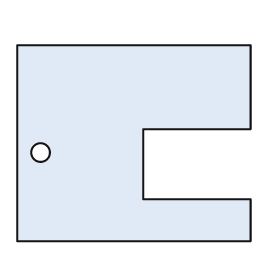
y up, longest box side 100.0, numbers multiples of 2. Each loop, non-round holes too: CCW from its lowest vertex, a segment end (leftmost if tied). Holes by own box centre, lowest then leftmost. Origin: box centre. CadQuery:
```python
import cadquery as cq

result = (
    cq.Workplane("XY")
    .moveTo(-50.0, -42.0)
    .lineTo(50.0, -42.0)
    .lineTo(50.0, -24.0)
    .lineTo(4.0, -24.0)
    .lineTo(4.0, 6.0)
    .lineTo(50.0, 6.0)
    .lineTo(50.0, 42.0)
    .lineTo(-50.0, 42.0)
    .close()
    .moveTo(-40.0, -4.0)
    .circle(4.0)
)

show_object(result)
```